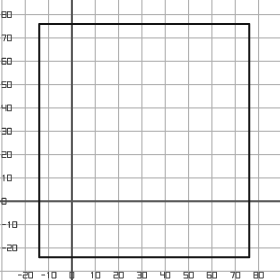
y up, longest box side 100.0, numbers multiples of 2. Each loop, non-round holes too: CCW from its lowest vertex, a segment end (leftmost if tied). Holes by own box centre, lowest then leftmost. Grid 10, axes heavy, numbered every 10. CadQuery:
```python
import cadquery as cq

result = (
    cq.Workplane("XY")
    .moveTo(-14.0, -24.0)
    .lineTo(76.0, -24.0)
    .lineTo(76.0, 76.0)
    .lineTo(-14.0, 76.0)
    .close()
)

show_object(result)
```